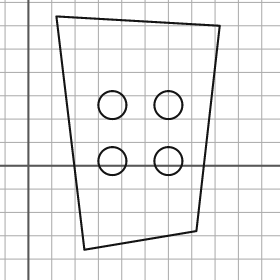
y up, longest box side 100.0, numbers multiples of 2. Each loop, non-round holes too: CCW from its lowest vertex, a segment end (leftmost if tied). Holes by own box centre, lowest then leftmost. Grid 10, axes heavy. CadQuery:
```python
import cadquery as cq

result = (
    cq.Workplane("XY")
    .moveTo(24.0, -36.0)
    .lineTo(72.0, -28.0)
    .lineTo(82.0, 60.0)
    .lineTo(12.0, 64.0)
    .close()
    .moveTo(36.0, 2.0)
    .circle(6.0)
    .moveTo(60.0, 2.0)
    .circle(6.0)
    .moveTo(36.0, 26.0)
    .circle(6.0)
    .moveTo(60.0, 26.0)
    .circle(6.0)
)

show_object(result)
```